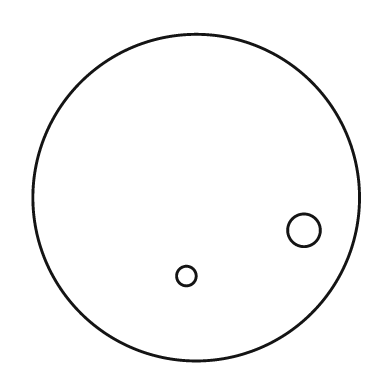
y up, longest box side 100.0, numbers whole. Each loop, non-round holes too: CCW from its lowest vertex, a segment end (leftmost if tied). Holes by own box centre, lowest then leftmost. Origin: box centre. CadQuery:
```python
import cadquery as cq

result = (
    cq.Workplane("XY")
    .moveTo(0.0, 0.0)
    .circle(50.0)
    .moveTo(-3.0, -24.0)
    .circle(3.0)
    .moveTo(33.0, -10.0)
    .circle(5.0)
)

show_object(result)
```